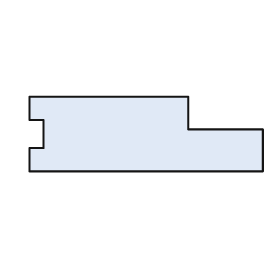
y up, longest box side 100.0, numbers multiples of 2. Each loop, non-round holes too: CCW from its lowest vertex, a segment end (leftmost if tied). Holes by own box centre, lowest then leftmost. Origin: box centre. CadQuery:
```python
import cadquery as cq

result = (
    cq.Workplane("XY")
    .moveTo(-50.0, -16.0)
    .lineTo(50.0, -16.0)
    .lineTo(50.0, 2.0)
    .lineTo(18.0, 2.0)
    .lineTo(18.0, 16.0)
    .lineTo(-50.0, 16.0)
    .lineTo(-50.0, 6.0)
    .lineTo(-44.0, 6.0)
    .lineTo(-44.0, -6.0)
    .lineTo(-50.0, -6.0)
    .close()
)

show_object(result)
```